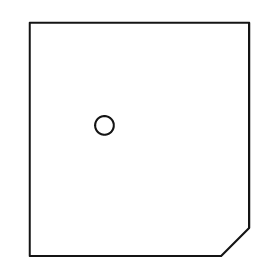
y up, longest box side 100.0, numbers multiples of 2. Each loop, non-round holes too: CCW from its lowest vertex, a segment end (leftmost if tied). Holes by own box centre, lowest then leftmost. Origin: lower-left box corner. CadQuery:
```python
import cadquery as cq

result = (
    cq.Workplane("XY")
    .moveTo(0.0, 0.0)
    .lineTo(82.0, 0.0)
    .lineTo(94.0, 12.0)
    .lineTo(94.0, 100.0)
    .lineTo(0.0, 100.0)
    .close()
    .moveTo(32.0, 56.0)
    .circle(4.0)
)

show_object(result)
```